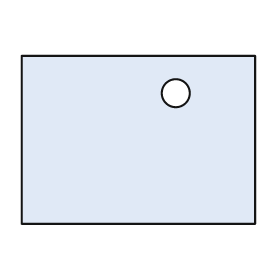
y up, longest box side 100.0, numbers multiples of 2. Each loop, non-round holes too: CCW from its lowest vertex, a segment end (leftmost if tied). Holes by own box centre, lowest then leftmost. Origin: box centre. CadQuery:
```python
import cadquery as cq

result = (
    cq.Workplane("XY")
    .moveTo(-50.0, -36.0)
    .lineTo(50.0, -36.0)
    .lineTo(50.0, 36.0)
    .lineTo(-50.0, 36.0)
    .close()
    .moveTo(16.0, 20.0)
    .circle(6.0)
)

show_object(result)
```